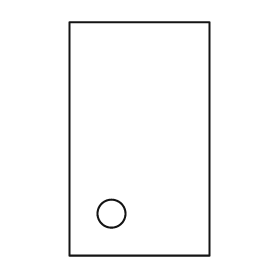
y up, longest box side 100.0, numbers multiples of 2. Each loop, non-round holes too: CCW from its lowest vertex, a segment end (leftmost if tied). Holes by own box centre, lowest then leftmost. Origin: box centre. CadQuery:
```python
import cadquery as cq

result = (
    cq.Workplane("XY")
    .moveTo(-30.0, -50.0)
    .lineTo(30.0, -50.0)
    .lineTo(30.0, 50.0)
    .lineTo(-30.0, 50.0)
    .close()
    .moveTo(-12.0, -32.0)
    .circle(6.0)
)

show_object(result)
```